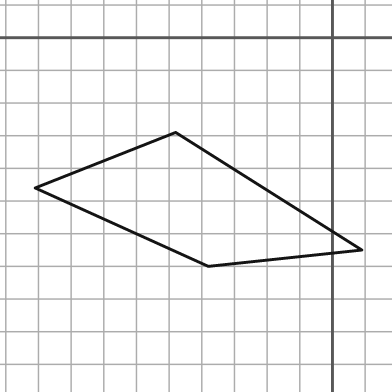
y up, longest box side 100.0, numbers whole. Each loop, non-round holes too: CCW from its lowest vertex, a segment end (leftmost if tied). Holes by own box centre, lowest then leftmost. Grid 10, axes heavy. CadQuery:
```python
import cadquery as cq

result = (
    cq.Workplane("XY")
    .moveTo(-38.0, -70.0)
    .lineTo(9.0, -65.0)
    .lineTo(-48.0, -29.0)
    .lineTo(-91.0, -46.0)
    .close()
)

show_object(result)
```